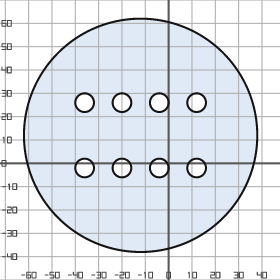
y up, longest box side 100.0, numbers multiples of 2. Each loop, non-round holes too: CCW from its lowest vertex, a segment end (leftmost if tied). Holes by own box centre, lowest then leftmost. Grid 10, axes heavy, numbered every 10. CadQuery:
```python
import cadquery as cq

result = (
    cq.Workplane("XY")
    .moveTo(-12.0, 12.0)
    .circle(50.0)
    .moveTo(-36.0, -2.0)
    .circle(4.0)
    .moveTo(-20.0, -2.0)
    .circle(4.0)
    .moveTo(-4.0, -2.0)
    .circle(4.0)
    .moveTo(12.0, -2.0)
    .circle(4.0)
    .moveTo(-36.0, 26.0)
    .circle(4.0)
    .moveTo(-20.0, 26.0)
    .circle(4.0)
    .moveTo(-4.0, 26.0)
    .circle(4.0)
    .moveTo(12.0, 26.0)
    .circle(4.0)
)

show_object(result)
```